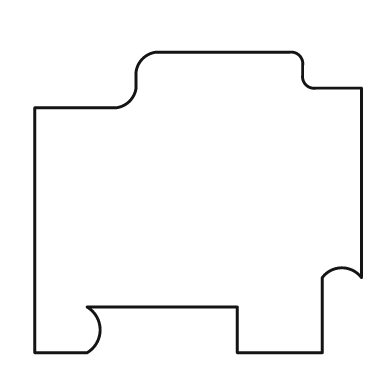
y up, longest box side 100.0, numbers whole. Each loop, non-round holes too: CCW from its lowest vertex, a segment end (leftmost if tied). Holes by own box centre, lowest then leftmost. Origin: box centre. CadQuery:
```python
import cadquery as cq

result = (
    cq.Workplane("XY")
    .moveTo(-50.0, -46.0)
    .lineTo(-34.0, -46.0)
    .threePointArc((-30.0, -39.0), (-34.0, -32.0))
    .lineTo(12.0, -32.0)
    .lineTo(12.0, -46.0)
    .lineTo(38.0, -46.0)
    .lineTo(38.0, -23.0)
    .threePointArc((44.0, -20.0), (50.0, -23.0))
    .lineTo(50.0, 35.0)
    .lineTo(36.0, 35.0)
    .threePointArc((33.0, 36.0), (32.0, 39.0))
    .lineTo(32.0, 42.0)
    .threePointArc((31.0, 45.0), (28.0, 46.0))
    .lineTo(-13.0, 46.0)
    .threePointArc((-17.0, 44.0), (-19.0, 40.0))
    .lineTo(-19.0, 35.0)
    .threePointArc((-21.0, 31.0), (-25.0, 29.0))
    .lineTo(-50.0, 29.0)
    .close()
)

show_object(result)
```